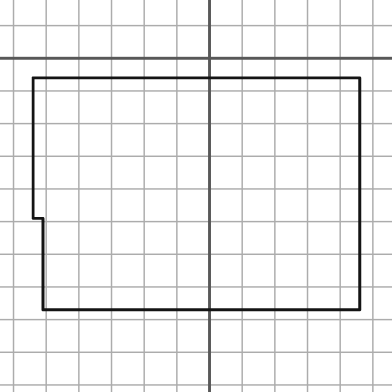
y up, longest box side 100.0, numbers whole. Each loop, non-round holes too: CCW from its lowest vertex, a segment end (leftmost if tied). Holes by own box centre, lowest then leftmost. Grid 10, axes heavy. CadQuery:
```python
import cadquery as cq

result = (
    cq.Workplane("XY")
    .moveTo(-51.0, -77.0)
    .lineTo(46.0, -77.0)
    .lineTo(46.0, -6.0)
    .lineTo(-54.0, -6.0)
    .lineTo(-54.0, -49.0)
    .lineTo(-51.0, -49.0)
    .close()
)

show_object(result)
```